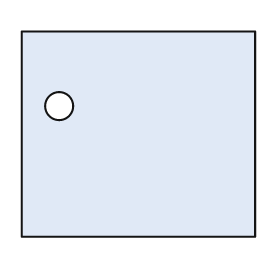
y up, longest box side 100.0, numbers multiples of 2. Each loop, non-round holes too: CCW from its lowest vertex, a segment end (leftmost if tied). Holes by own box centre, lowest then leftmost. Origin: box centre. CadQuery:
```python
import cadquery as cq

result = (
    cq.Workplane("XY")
    .moveTo(-50.0, -44.0)
    .lineTo(50.0, -44.0)
    .lineTo(50.0, 44.0)
    .lineTo(-50.0, 44.0)
    .close()
    .moveTo(-34.0, 12.0)
    .circle(6.0)
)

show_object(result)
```